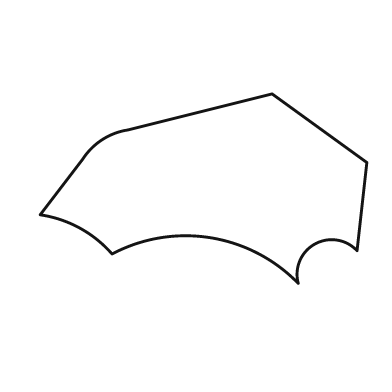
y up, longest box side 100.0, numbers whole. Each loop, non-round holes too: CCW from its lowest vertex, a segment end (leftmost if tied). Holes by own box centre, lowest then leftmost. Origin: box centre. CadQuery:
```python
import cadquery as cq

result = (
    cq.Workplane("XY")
    .moveTo(29.0, -29.0)
    .threePointArc((34.0, -17.0), (47.0, -19.0))
    .lineTo(50.0, 8.0)
    .lineTo(21.0, 29.0)
    .lineTo(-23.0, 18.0)
    .threePointArc((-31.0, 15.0), (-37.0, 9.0))
    .lineTo(-50.0, -8.0)
    .threePointArc((-38.0, -12.0), (-28.0, -20.0))
    .threePointArc((2.0, -15.0), (29.0, -29.0))
    .close()
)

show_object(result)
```